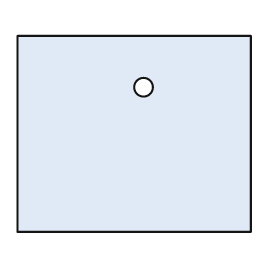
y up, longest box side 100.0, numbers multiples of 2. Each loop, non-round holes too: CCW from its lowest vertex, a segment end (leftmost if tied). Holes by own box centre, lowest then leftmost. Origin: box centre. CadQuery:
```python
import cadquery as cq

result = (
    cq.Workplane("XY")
    .moveTo(-50.0, -42.0)
    .lineTo(50.0, -42.0)
    .lineTo(50.0, 42.0)
    .lineTo(-50.0, 42.0)
    .close()
    .moveTo(4.0, 20.0)
    .circle(4.0)
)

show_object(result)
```